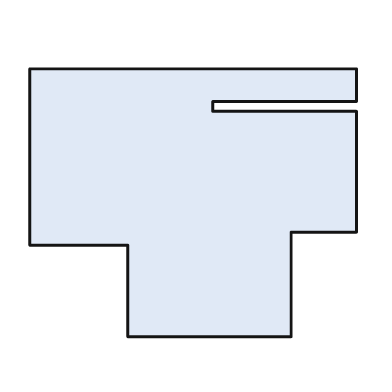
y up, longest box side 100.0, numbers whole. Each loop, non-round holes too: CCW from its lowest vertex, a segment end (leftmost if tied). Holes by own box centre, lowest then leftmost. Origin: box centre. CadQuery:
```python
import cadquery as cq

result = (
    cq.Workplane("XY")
    .moveTo(-20.0, -41.0)
    .lineTo(30.0, -41.0)
    .lineTo(30.0, -9.0)
    .lineTo(50.0, -9.0)
    .lineTo(50.0, 28.0)
    .lineTo(6.0, 28.0)
    .lineTo(6.0, 31.0)
    .lineTo(50.0, 31.0)
    .lineTo(50.0, 41.0)
    .lineTo(-50.0, 41.0)
    .lineTo(-50.0, -13.0)
    .lineTo(-20.0, -13.0)
    .close()
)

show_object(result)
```